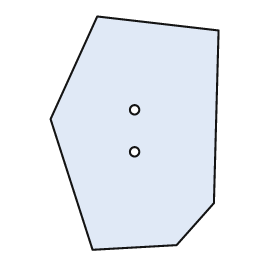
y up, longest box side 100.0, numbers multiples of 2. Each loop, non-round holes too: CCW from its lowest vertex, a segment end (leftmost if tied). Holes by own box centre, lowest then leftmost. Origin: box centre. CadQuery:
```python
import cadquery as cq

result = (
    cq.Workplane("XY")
    .moveTo(-18.0, -50.0)
    .lineTo(18.0, -48.0)
    .lineTo(34.0, -30.0)
    .lineTo(36.0, 44.0)
    .lineTo(-16.0, 50.0)
    .lineTo(-36.0, 6.0)
    .close()
    .moveTo(0.0, -8.0)
    .circle(2.0)
    .moveTo(0.0, 10.0)
    .circle(2.0)
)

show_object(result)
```